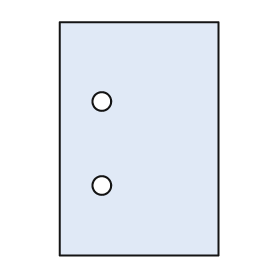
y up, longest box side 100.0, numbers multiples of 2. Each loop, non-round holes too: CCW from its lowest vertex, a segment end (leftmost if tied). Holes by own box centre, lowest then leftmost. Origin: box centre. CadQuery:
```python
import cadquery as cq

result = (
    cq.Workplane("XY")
    .moveTo(-34.0, -50.0)
    .lineTo(34.0, -50.0)
    .lineTo(34.0, 50.0)
    .lineTo(-34.0, 50.0)
    .close()
    .moveTo(-16.0, -20.0)
    .circle(4.0)
    .moveTo(-16.0, 16.0)
    .circle(4.0)
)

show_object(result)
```